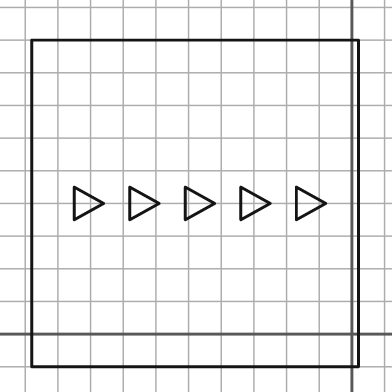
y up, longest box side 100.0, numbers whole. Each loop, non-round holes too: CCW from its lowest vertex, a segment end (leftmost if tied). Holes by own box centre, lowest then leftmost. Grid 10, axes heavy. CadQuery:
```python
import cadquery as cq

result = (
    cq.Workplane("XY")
    .moveTo(-98.0, -10.0)
    .lineTo(2.0, -10.0)
    .lineTo(2.0, 90.0)
    .lineTo(-98.0, 90.0)
    .close()
    .moveTo(-85.0, 35.0)
    .lineTo(-76.0, 40.0)
    .lineTo(-85.0, 45.0)
    .close()
    .moveTo(-68.0, 35.0)
    .lineTo(-59.0, 40.0)
    .lineTo(-68.0, 45.0)
    .close()
    .moveTo(-51.0, 35.0)
    .lineTo(-42.0, 40.0)
    .lineTo(-51.0, 45.0)
    .close()
    .moveTo(-34.0, 35.0)
    .lineTo(-25.0, 40.0)
    .lineTo(-34.0, 45.0)
    .close()
    .moveTo(-17.0, 35.0)
    .lineTo(-8.0, 40.0)
    .lineTo(-17.0, 45.0)
    .close()
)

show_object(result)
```